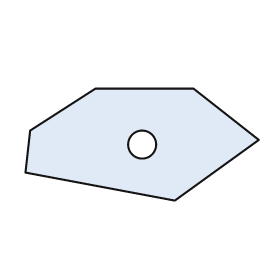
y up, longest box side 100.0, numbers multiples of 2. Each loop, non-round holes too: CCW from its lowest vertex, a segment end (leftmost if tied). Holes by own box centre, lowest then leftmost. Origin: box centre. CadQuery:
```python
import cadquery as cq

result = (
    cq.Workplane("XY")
    .moveTo(14.0, -24.0)
    .lineTo(50.0, 2.0)
    .lineTo(22.0, 24.0)
    .lineTo(-20.0, 24.0)
    .lineTo(-48.0, 6.0)
    .lineTo(-50.0, -12.0)
    .close()
    .moveTo(0.0, 0.0)
    .circle(6.0)
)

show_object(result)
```